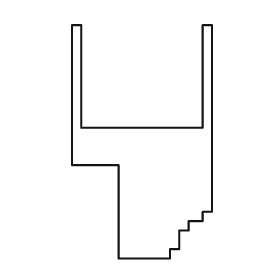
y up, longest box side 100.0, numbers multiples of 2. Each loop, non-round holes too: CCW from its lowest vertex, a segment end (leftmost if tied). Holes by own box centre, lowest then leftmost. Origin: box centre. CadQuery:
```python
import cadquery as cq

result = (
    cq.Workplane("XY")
    .moveTo(-10.0, -50.0)
    .lineTo(12.0, -50.0)
    .lineTo(12.0, -46.0)
    .lineTo(16.0, -46.0)
    .lineTo(16.0, -38.0)
    .lineTo(20.0, -38.0)
    .lineTo(20.0, -34.0)
    .lineTo(26.0, -34.0)
    .lineTo(26.0, -30.0)
    .lineTo(30.0, -30.0)
    .lineTo(30.0, 50.0)
    .lineTo(26.0, 50.0)
    .lineTo(26.0, 6.0)
    .lineTo(-26.0, 6.0)
    .lineTo(-26.0, 50.0)
    .lineTo(-30.0, 50.0)
    .lineTo(-30.0, -10.0)
    .lineTo(-10.0, -10.0)
    .close()
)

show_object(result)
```